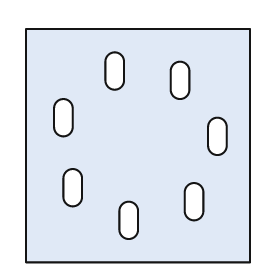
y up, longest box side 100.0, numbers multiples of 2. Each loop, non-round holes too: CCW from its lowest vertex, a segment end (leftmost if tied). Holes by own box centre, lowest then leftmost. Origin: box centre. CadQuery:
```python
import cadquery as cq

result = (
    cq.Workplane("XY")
    .moveTo(-48.0, -50.0)
    .lineTo(48.0, -50.0)
    .lineTo(48.0, 50.0)
    .lineTo(-48.0, 50.0)
    .close()
    .moveTo(-8.0, -36.0)
    .threePointArc((-4.0, -40.0), (0.0, -36.0))
    .lineTo(0.0, -28.0)
    .threePointArc((-4.0, -24.0), (-8.0, -28.0))
    .close()
    .moveTo(20.0, -28.0)
    .threePointArc((24.0, -32.0), (28.0, -28.0))
    .lineTo(28.0, -20.0)
    .threePointArc((24.0, -16.0), (20.0, -20.0))
    .close()
    .moveTo(-32.0, -22.0)
    .threePointArc((-28.0, -26.0), (-24.0, -22.0))
    .lineTo(-24.0, -14.0)
    .threePointArc((-28.0, -10.0), (-32.0, -14.0))
    .close()
    .moveTo(30.0, 0.0)
    .threePointArc((34.0, -4.0), (38.0, 0.0))
    .lineTo(38.0, 8.0)
    .threePointArc((34.0, 12.0), (30.0, 8.0))
    .close()
    .moveTo(-36.0, 8.0)
    .threePointArc((-32.0, 4.0), (-28.0, 8.0))
    .lineTo(-28.0, 16.0)
    .threePointArc((-32.0, 20.0), (-36.0, 16.0))
    .close()
    .moveTo(14.0, 24.0)
    .threePointArc((18.0, 20.0), (22.0, 24.0))
    .lineTo(22.0, 32.0)
    .threePointArc((18.0, 36.0), (14.0, 32.0))
    .close()
    .moveTo(-14.0, 28.0)
    .threePointArc((-10.0, 24.0), (-6.0, 28.0))
    .lineTo(-6.0, 36.0)
    .threePointArc((-10.0, 40.0), (-14.0, 36.0))
    .close()
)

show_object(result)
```